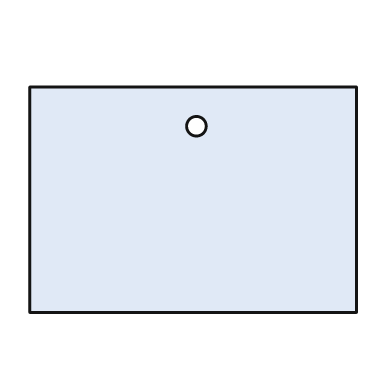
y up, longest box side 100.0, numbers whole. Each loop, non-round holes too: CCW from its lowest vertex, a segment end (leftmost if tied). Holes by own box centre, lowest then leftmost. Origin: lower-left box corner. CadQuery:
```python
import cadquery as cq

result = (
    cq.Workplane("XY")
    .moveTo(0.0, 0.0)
    .lineTo(100.0, 0.0)
    .lineTo(100.0, 69.0)
    .lineTo(0.0, 69.0)
    .close()
    .moveTo(51.0, 57.0)
    .circle(3.0)
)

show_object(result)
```